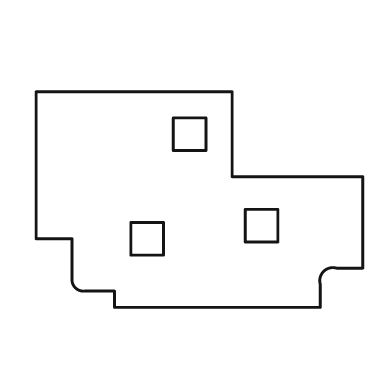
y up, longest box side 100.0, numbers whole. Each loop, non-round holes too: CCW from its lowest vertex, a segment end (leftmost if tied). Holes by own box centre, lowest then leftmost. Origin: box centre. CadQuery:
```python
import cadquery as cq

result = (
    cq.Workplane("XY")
    .moveTo(-26.0, -33.0)
    .lineTo(37.0, -33.0)
    .lineTo(37.0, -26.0)
    .threePointArc((38.0, -22.0), (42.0, -21.0))
    .lineTo(50.0, -21.0)
    .lineTo(50.0, 7.0)
    .lineTo(10.0, 7.0)
    .lineTo(10.0, 33.0)
    .lineTo(-50.0, 33.0)
    .lineTo(-50.0, -12.0)
    .lineTo(-39.0, -12.0)
    .lineTo(-39.0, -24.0)
    .threePointArc((-38.0, -27.0), (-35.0, -28.0))
    .lineTo(-26.0, -28.0)
    .close()
    .moveTo(-21.0, -17.0)
    .lineTo(-11.0, -17.0)
    .lineTo(-11.0, -7.0)
    .lineTo(-21.0, -7.0)
    .close()
    .moveTo(14.0, -13.0)
    .lineTo(24.0, -13.0)
    .lineTo(24.0, -3.0)
    .lineTo(14.0, -3.0)
    .close()
    .moveTo(-8.0, 15.0)
    .lineTo(2.0, 15.0)
    .lineTo(2.0, 25.0)
    .lineTo(-8.0, 25.0)
    .close()
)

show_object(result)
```